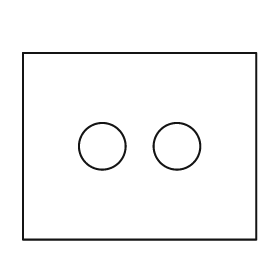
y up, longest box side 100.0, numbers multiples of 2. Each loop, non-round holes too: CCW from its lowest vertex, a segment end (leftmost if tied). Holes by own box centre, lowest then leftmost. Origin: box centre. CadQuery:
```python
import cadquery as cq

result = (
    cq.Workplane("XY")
    .moveTo(-50.0, -40.0)
    .lineTo(50.0, -40.0)
    .lineTo(50.0, 40.0)
    .lineTo(-50.0, 40.0)
    .close()
    .moveTo(-16.0, 0.0)
    .circle(10.0)
    .moveTo(16.0, 0.0)
    .circle(10.0)
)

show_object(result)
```